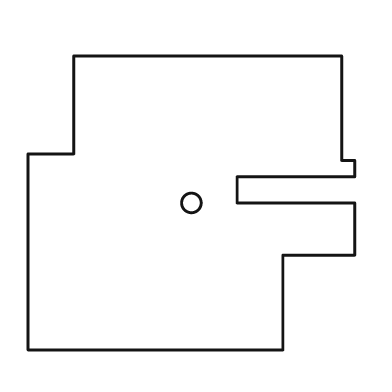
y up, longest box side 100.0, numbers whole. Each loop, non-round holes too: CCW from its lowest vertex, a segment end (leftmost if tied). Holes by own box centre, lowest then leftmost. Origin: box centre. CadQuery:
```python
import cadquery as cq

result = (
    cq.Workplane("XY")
    .moveTo(-50.0, -45.0)
    .lineTo(28.0, -45.0)
    .lineTo(28.0, -16.0)
    .lineTo(50.0, -16.0)
    .lineTo(50.0, 0.0)
    .lineTo(14.0, 0.0)
    .lineTo(14.0, 8.0)
    .lineTo(50.0, 8.0)
    .lineTo(50.0, 13.0)
    .lineTo(46.0, 13.0)
    .lineTo(46.0, 45.0)
    .lineTo(-36.0, 45.0)
    .lineTo(-36.0, 15.0)
    .lineTo(-50.0, 15.0)
    .close()
    .moveTo(0.0, 0.0)
    .circle(3.0)
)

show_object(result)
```